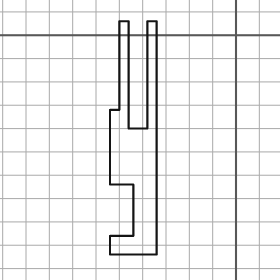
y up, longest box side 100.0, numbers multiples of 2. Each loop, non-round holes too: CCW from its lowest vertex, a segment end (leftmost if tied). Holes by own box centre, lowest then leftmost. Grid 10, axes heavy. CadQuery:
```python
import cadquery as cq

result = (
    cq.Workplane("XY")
    .moveTo(-54.0, -94.0)
    .lineTo(-34.0, -94.0)
    .lineTo(-34.0, 6.0)
    .lineTo(-38.0, 6.0)
    .lineTo(-38.0, -40.0)
    .lineTo(-46.0, -40.0)
    .lineTo(-46.0, 6.0)
    .lineTo(-50.0, 6.0)
    .lineTo(-50.0, -32.0)
    .lineTo(-54.0, -32.0)
    .lineTo(-54.0, -64.0)
    .lineTo(-44.0, -64.0)
    .lineTo(-44.0, -86.0)
    .lineTo(-54.0, -86.0)
    .close()
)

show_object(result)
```